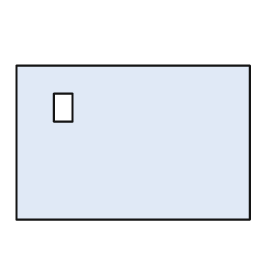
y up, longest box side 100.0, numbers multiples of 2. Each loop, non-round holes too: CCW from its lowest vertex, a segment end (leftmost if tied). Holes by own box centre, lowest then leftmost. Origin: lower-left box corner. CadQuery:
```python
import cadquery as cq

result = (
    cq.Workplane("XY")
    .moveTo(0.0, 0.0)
    .lineTo(100.0, 0.0)
    .lineTo(100.0, 66.0)
    .lineTo(0.0, 66.0)
    .close()
    .moveTo(16.0, 42.0)
    .lineTo(24.0, 42.0)
    .lineTo(24.0, 54.0)
    .lineTo(16.0, 54.0)
    .close()
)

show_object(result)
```